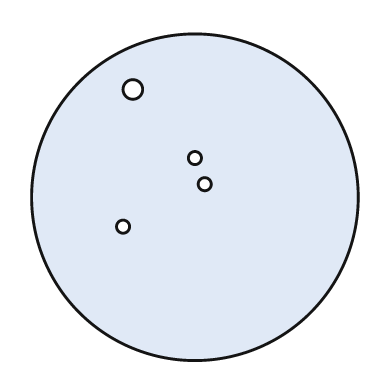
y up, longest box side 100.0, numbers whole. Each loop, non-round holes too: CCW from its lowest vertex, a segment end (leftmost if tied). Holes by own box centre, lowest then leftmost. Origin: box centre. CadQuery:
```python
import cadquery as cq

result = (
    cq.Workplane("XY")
    .moveTo(0.0, 0.0)
    .circle(50.0)
    .moveTo(-22.0, -9.0)
    .circle(2.0)
    .moveTo(3.0, 4.0)
    .circle(2.0)
    .moveTo(0.0, 12.0)
    .circle(2.0)
    .moveTo(-19.0, 33.0)
    .circle(3.0)
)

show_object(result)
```